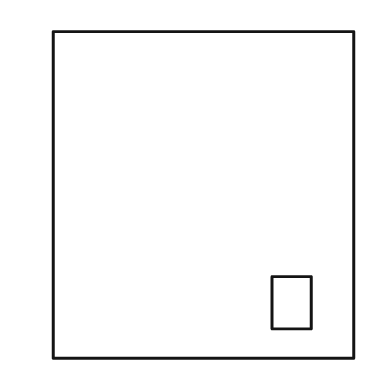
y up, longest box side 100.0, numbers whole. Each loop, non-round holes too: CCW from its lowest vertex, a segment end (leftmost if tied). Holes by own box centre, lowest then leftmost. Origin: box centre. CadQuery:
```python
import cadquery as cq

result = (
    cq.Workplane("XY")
    .moveTo(-46.0, -50.0)
    .lineTo(46.0, -50.0)
    .lineTo(46.0, 50.0)
    .lineTo(-46.0, 50.0)
    .close()
    .moveTo(21.0, -41.0)
    .lineTo(33.0, -41.0)
    .lineTo(33.0, -25.0)
    .lineTo(21.0, -25.0)
    .close()
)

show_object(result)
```